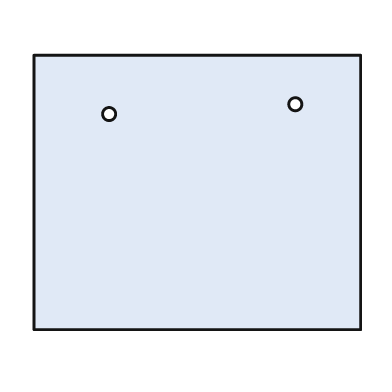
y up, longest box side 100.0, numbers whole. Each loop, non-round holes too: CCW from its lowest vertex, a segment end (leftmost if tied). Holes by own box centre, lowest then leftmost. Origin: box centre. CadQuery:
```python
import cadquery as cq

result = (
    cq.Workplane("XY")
    .moveTo(-50.0, -42.0)
    .lineTo(50.0, -42.0)
    .lineTo(50.0, 42.0)
    .lineTo(-50.0, 42.0)
    .close()
    .moveTo(-27.0, 24.0)
    .circle(2.0)
    .moveTo(30.0, 27.0)
    .circle(2.0)
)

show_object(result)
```